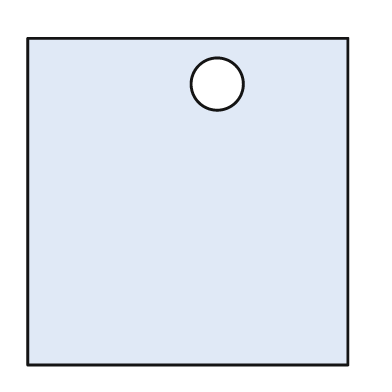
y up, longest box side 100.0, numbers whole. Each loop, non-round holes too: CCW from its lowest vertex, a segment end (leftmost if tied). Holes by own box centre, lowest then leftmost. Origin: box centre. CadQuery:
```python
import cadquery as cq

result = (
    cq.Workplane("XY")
    .moveTo(-49.0, -50.0)
    .lineTo(49.0, -50.0)
    .lineTo(49.0, 50.0)
    .lineTo(-49.0, 50.0)
    .close()
    .moveTo(9.0, 36.0)
    .circle(8.0)
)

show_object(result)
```